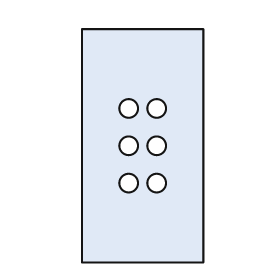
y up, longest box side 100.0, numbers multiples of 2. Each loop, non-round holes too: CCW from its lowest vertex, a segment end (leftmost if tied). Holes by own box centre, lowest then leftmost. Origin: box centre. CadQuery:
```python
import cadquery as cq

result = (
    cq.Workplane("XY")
    .moveTo(-26.0, -50.0)
    .lineTo(26.0, -50.0)
    .lineTo(26.0, 50.0)
    .lineTo(-26.0, 50.0)
    .close()
    .moveTo(-6.0, -16.0)
    .circle(4.0)
    .moveTo(6.0, -16.0)
    .circle(4.0)
    .moveTo(-6.0, 0.0)
    .circle(4.0)
    .moveTo(6.0, 0.0)
    .circle(4.0)
    .moveTo(-6.0, 16.0)
    .circle(4.0)
    .moveTo(6.0, 16.0)
    .circle(4.0)
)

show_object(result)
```